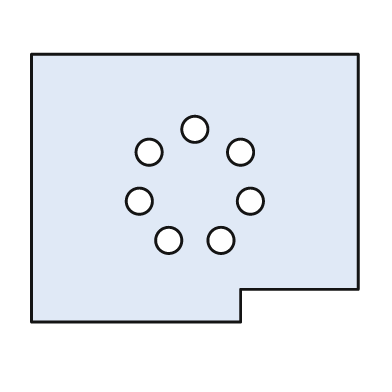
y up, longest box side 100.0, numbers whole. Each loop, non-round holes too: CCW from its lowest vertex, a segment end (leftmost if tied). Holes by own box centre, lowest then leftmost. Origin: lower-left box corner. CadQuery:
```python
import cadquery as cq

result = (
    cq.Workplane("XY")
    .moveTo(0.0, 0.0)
    .lineTo(64.0, 0.0)
    .lineTo(64.0, 10.0)
    .lineTo(100.0, 10.0)
    .lineTo(100.0, 82.0)
    .lineTo(0.0, 82.0)
    .close()
    .moveTo(42.0, 25.0)
    .circle(4.0)
    .moveTo(58.0, 25.0)
    .circle(4.0)
    .moveTo(33.0, 37.0)
    .circle(4.0)
    .moveTo(67.0, 37.0)
    .circle(4.0)
    .moveTo(36.0, 52.0)
    .circle(4.0)
    .moveTo(64.0, 52.0)
    .circle(4.0)
    .moveTo(50.0, 59.0)
    .circle(4.0)
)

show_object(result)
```